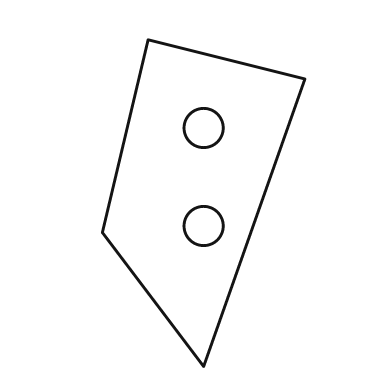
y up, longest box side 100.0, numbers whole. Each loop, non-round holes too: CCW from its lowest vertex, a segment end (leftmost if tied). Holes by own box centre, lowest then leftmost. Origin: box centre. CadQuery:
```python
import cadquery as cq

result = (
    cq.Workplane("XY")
    .moveTo(0.0, -50.0)
    .lineTo(31.0, 38.0)
    .lineTo(-17.0, 50.0)
    .lineTo(-31.0, -9.0)
    .close()
    .moveTo(0.0, -7.0)
    .circle(6.0)
    .moveTo(0.0, 23.0)
    .circle(6.0)
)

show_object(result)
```